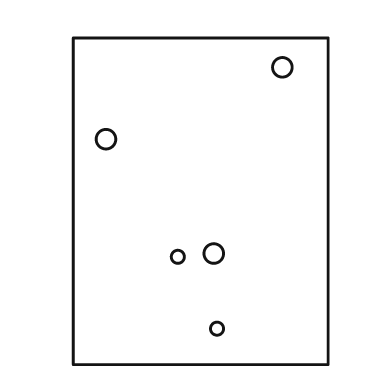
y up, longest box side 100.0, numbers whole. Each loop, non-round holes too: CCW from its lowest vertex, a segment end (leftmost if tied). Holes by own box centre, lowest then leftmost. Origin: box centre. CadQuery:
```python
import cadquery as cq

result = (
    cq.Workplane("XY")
    .moveTo(-39.0, -50.0)
    .lineTo(39.0, -50.0)
    .lineTo(39.0, 50.0)
    .lineTo(-39.0, 50.0)
    .close()
    .moveTo(5.0, -39.0)
    .circle(2.0)
    .moveTo(-7.0, -17.0)
    .circle(2.0)
    .moveTo(4.0, -16.0)
    .circle(3.0)
    .moveTo(-29.0, 19.0)
    .circle(3.0)
    .moveTo(25.0, 41.0)
    .circle(3.0)
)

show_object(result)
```